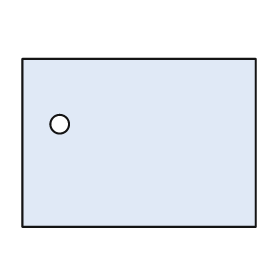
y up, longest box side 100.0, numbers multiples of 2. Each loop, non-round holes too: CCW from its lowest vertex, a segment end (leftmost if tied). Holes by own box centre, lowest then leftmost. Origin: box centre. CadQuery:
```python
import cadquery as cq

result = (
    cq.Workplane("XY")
    .moveTo(-50.0, -36.0)
    .lineTo(50.0, -36.0)
    .lineTo(50.0, 36.0)
    .lineTo(-50.0, 36.0)
    .close()
    .moveTo(-34.0, 8.0)
    .circle(4.0)
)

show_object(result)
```